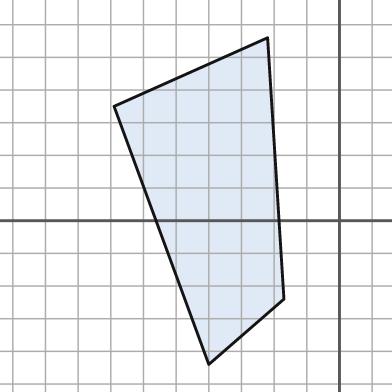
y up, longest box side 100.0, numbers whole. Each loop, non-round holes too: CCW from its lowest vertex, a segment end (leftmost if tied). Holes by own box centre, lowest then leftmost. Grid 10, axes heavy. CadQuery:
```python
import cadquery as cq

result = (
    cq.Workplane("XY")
    .moveTo(-40.0, -44.0)
    .lineTo(-17.0, -24.0)
    .lineTo(-22.0, 56.0)
    .lineTo(-69.0, 35.0)
    .close()
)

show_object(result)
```